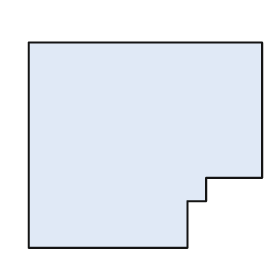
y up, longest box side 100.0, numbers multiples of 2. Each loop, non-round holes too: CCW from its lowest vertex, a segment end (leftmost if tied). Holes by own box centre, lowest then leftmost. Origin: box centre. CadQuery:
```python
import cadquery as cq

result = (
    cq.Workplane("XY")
    .moveTo(-50.0, -44.0)
    .lineTo(18.0, -44.0)
    .lineTo(18.0, -24.0)
    .lineTo(26.0, -24.0)
    .lineTo(26.0, -14.0)
    .lineTo(50.0, -14.0)
    .lineTo(50.0, 44.0)
    .lineTo(-50.0, 44.0)
    .close()
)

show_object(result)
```